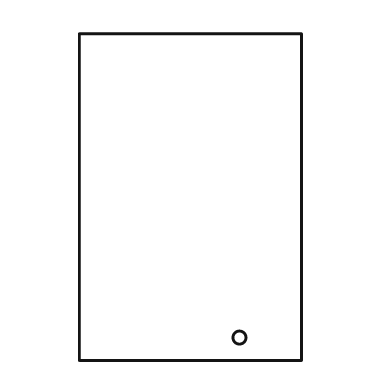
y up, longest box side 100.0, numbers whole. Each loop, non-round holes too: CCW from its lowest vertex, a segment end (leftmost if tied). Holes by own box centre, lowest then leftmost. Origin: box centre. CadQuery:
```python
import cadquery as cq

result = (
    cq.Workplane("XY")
    .moveTo(-34.0, -50.0)
    .lineTo(34.0, -50.0)
    .lineTo(34.0, 50.0)
    .lineTo(-34.0, 50.0)
    .close()
    .moveTo(15.0, -43.0)
    .circle(2.0)
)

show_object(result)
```